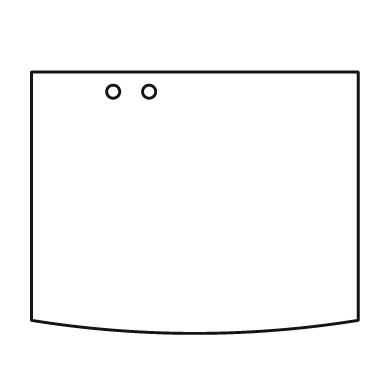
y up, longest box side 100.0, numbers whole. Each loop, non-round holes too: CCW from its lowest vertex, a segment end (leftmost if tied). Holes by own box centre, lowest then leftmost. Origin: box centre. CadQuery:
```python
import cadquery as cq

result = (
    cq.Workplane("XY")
    .moveTo(-50.0, -36.0)
    .threePointArc((0.0, -40.0), (50.0, -36.0))
    .lineTo(50.0, 40.0)
    .lineTo(-50.0, 40.0)
    .close()
    .moveTo(-25.0, 34.0)
    .circle(2.0)
    .moveTo(-14.0, 34.0)
    .circle(2.0)
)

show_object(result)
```